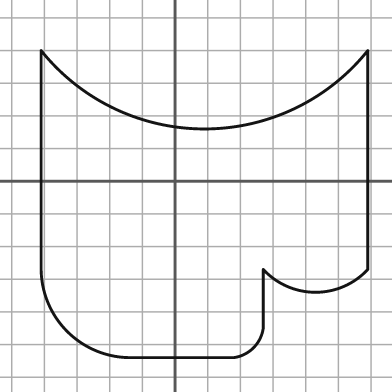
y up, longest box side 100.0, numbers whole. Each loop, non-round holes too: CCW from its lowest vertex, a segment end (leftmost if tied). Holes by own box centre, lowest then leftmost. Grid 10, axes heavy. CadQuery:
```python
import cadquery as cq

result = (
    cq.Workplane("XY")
    .moveTo(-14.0, -54.0)
    .lineTo(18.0, -54.0)
    .threePointArc((24.0, -51.0), (27.0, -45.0))
    .lineTo(27.0, -27.0)
    .threePointArc((43.0, -34.0), (59.0, -27.0))
    .lineTo(59.0, 40.0)
    .threePointArc((9.0, 16.0), (-41.0, 40.0))
    .lineTo(-41.0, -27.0)
    .threePointArc((-33.0, -46.0), (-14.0, -54.0))
    .close()
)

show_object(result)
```